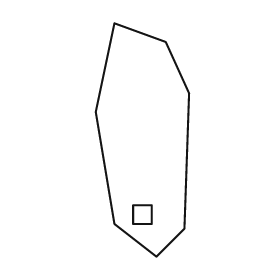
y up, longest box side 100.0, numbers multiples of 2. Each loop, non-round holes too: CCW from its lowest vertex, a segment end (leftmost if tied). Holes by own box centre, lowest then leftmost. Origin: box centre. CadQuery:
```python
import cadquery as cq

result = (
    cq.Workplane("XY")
    .moveTo(6.0, -50.0)
    .lineTo(18.0, -38.0)
    .lineTo(20.0, 20.0)
    .lineTo(10.0, 42.0)
    .lineTo(-12.0, 50.0)
    .lineTo(-20.0, 12.0)
    .lineTo(-12.0, -36.0)
    .close()
    .moveTo(-4.0, -36.0)
    .lineTo(4.0, -36.0)
    .lineTo(4.0, -28.0)
    .lineTo(-4.0, -28.0)
    .close()
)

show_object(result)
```